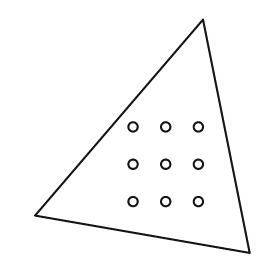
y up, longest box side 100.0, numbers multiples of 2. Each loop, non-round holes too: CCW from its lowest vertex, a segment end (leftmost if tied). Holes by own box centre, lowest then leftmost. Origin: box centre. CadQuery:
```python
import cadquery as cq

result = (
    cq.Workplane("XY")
    .moveTo(46.0, -50.0)
    .lineTo(26.0, 50.0)
    .lineTo(-46.0, -34.0)
    .close()
    .moveTo(-4.0, -28.0)
    .circle(2.0)
    .moveTo(10.0, -28.0)
    .circle(2.0)
    .moveTo(24.0, -28.0)
    .circle(2.0)
    .moveTo(-4.0, -12.0)
    .circle(2.0)
    .moveTo(10.0, -12.0)
    .circle(2.0)
    .moveTo(24.0, -12.0)
    .circle(2.0)
    .moveTo(-4.0, 4.0)
    .circle(2.0)
    .moveTo(10.0, 4.0)
    .circle(2.0)
    .moveTo(24.0, 4.0)
    .circle(2.0)
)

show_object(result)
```